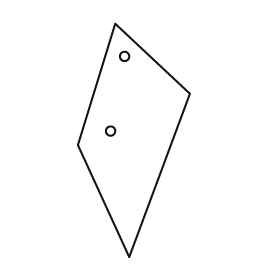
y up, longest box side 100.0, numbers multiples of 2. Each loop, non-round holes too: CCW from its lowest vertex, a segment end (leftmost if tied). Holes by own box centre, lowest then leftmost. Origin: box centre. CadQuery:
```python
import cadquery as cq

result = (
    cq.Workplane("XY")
    .moveTo(-2.0, -50.0)
    .lineTo(24.0, 20.0)
    .lineTo(-8.0, 50.0)
    .lineTo(-24.0, -2.0)
    .close()
    .moveTo(-10.0, 4.0)
    .circle(2.0)
    .moveTo(-4.0, 36.0)
    .circle(2.0)
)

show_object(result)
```